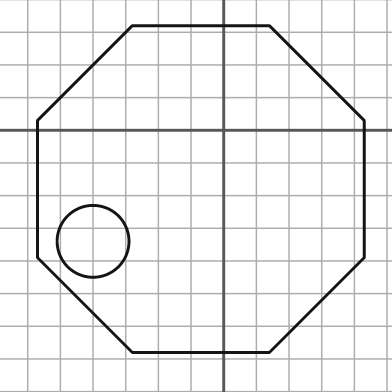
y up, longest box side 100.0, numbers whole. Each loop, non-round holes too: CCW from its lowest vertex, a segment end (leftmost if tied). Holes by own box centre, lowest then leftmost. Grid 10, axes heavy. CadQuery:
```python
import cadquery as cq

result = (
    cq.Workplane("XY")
    .moveTo(-28.0, -68.0)
    .lineTo(14.0, -68.0)
    .lineTo(43.0, -39.0)
    .lineTo(43.0, 3.0)
    .lineTo(14.0, 32.0)
    .lineTo(-28.0, 32.0)
    .lineTo(-57.0, 3.0)
    .lineTo(-57.0, -39.0)
    .close()
    .moveTo(-40.0, -34.0)
    .circle(11.0)
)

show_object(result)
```